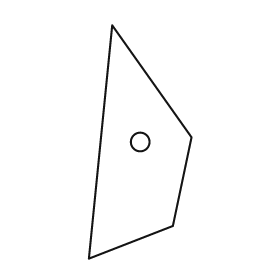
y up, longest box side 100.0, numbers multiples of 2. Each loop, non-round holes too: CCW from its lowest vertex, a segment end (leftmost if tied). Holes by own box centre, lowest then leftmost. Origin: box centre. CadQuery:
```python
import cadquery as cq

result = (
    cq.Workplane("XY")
    .moveTo(-22.0, -50.0)
    .lineTo(14.0, -36.0)
    .lineTo(22.0, 2.0)
    .lineTo(-12.0, 50.0)
    .close()
    .moveTo(0.0, 0.0)
    .circle(4.0)
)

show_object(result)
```